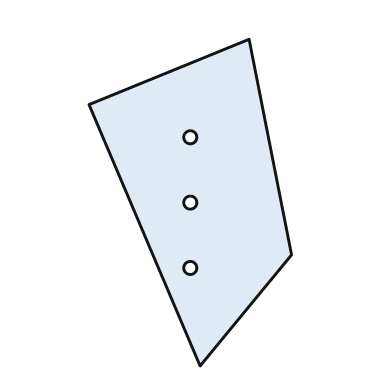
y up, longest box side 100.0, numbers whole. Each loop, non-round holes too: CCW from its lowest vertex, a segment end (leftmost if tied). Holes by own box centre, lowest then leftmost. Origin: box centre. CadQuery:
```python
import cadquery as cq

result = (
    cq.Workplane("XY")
    .moveTo(3.0, -50.0)
    .lineTo(31.0, -16.0)
    .lineTo(18.0, 50.0)
    .lineTo(-31.0, 30.0)
    .close()
    .moveTo(0.0, -20.0)
    .circle(2.0)
    .moveTo(0.0, 0.0)
    .circle(2.0)
    .moveTo(0.0, 20.0)
    .circle(2.0)
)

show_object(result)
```